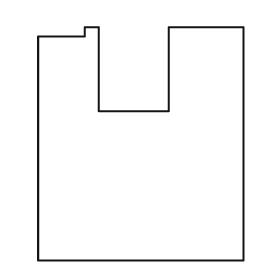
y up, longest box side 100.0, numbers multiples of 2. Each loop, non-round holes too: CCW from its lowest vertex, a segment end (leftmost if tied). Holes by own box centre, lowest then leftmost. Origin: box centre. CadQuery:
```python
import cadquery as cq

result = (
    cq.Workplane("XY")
    .moveTo(-44.0, -50.0)
    .lineTo(44.0, -50.0)
    .lineTo(44.0, 50.0)
    .lineTo(12.0, 50.0)
    .lineTo(12.0, 14.0)
    .lineTo(-18.0, 14.0)
    .lineTo(-18.0, 50.0)
    .lineTo(-24.0, 50.0)
    .lineTo(-24.0, 46.0)
    .lineTo(-44.0, 46.0)
    .close()
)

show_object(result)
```